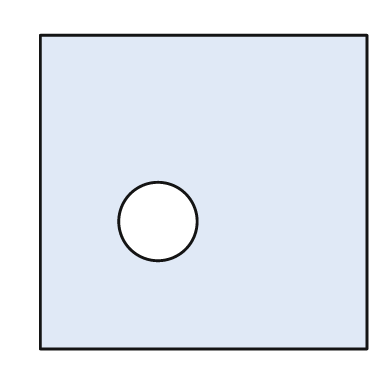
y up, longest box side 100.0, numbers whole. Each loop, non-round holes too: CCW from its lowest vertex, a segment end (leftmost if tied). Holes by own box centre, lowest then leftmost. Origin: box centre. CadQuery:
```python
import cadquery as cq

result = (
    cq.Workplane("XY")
    .moveTo(-50.0, -48.0)
    .lineTo(50.0, -48.0)
    .lineTo(50.0, 48.0)
    .lineTo(-50.0, 48.0)
    .close()
    .moveTo(-14.0, -9.0)
    .circle(12.0)
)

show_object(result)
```